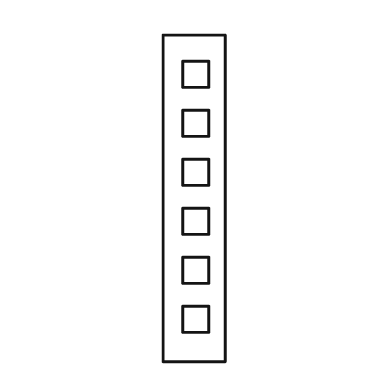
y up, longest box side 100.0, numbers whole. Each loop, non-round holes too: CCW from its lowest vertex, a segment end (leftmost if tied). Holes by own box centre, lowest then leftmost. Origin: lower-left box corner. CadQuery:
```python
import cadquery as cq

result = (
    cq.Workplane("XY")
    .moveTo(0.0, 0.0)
    .lineTo(19.0, 0.0)
    .lineTo(19.0, 100.0)
    .lineTo(0.0, 100.0)
    .close()
    .moveTo(6.0, 9.0)
    .lineTo(14.0, 9.0)
    .lineTo(14.0, 17.0)
    .lineTo(6.0, 17.0)
    .close()
    .moveTo(6.0, 24.0)
    .lineTo(14.0, 24.0)
    .lineTo(14.0, 32.0)
    .lineTo(6.0, 32.0)
    .close()
    .moveTo(6.0, 39.0)
    .lineTo(14.0, 39.0)
    .lineTo(14.0, 47.0)
    .lineTo(6.0, 47.0)
    .close()
    .moveTo(6.0, 54.0)
    .lineTo(14.0, 54.0)
    .lineTo(14.0, 62.0)
    .lineTo(6.0, 62.0)
    .close()
    .moveTo(6.0, 69.0)
    .lineTo(14.0, 69.0)
    .lineTo(14.0, 77.0)
    .lineTo(6.0, 77.0)
    .close()
    .moveTo(6.0, 84.0)
    .lineTo(14.0, 84.0)
    .lineTo(14.0, 92.0)
    .lineTo(6.0, 92.0)
    .close()
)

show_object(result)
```